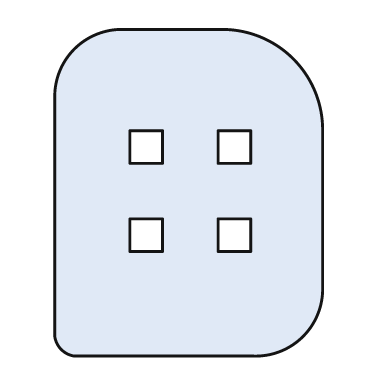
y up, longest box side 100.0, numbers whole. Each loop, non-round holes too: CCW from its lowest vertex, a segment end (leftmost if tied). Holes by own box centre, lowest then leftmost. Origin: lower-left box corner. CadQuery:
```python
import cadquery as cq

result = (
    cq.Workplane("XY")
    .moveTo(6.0, 0.0)
    .lineTo(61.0, 0.0)
    .threePointArc((76.0, 6.0), (82.0, 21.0))
    .lineTo(82.0, 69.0)
    .threePointArc((73.0, 91.0), (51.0, 100.0))
    .lineTo(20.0, 100.0)
    .threePointArc((6.0, 94.0), (0.0, 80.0))
    .lineTo(0.0, 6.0)
    .threePointArc((2.0, 2.0), (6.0, 0.0))
    .close()
    .moveTo(23.0, 32.0)
    .lineTo(33.0, 32.0)
    .lineTo(33.0, 42.0)
    .lineTo(23.0, 42.0)
    .close()
    .moveTo(50.0, 32.0)
    .lineTo(60.0, 32.0)
    .lineTo(60.0, 42.0)
    .lineTo(50.0, 42.0)
    .close()
    .moveTo(23.0, 59.0)
    .lineTo(33.0, 59.0)
    .lineTo(33.0, 69.0)
    .lineTo(23.0, 69.0)
    .close()
    .moveTo(50.0, 59.0)
    .lineTo(60.0, 59.0)
    .lineTo(60.0, 69.0)
    .lineTo(50.0, 69.0)
    .close()
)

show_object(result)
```